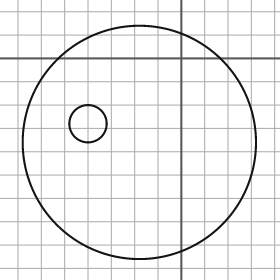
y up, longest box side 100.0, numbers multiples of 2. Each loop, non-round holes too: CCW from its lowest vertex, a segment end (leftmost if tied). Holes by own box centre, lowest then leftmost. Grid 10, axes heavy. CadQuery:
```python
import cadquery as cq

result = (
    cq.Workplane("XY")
    .moveTo(-18.0, -36.0)
    .circle(50.0)
    .moveTo(-40.0, -28.0)
    .circle(8.0)
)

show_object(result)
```